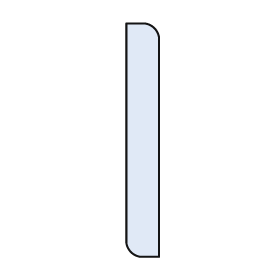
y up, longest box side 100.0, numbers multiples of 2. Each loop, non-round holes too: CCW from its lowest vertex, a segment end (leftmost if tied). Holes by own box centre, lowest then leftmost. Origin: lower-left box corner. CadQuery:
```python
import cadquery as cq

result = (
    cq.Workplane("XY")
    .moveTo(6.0, 0.0)
    .lineTo(14.0, 0.0)
    .lineTo(14.0, 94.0)
    .threePointArc((12.0, 98.0), (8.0, 100.0))
    .lineTo(0.0, 100.0)
    .lineTo(0.0, 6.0)
    .threePointArc((2.0, 2.0), (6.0, 0.0))
    .close()
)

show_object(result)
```